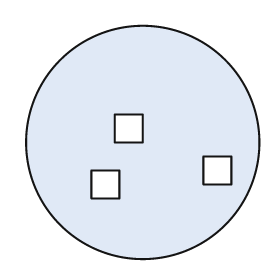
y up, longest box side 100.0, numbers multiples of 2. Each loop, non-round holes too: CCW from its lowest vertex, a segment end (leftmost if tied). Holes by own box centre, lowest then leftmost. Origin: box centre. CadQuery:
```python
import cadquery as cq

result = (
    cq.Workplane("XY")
    .moveTo(0.0, 0.0)
    .circle(50.0)
    .moveTo(-22.0, -24.0)
    .lineTo(-10.0, -24.0)
    .lineTo(-10.0, -12.0)
    .lineTo(-22.0, -12.0)
    .close()
    .moveTo(26.0, -18.0)
    .lineTo(38.0, -18.0)
    .lineTo(38.0, -6.0)
    .lineTo(26.0, -6.0)
    .close()
    .moveTo(-12.0, 0.0)
    .lineTo(0.0, 0.0)
    .lineTo(0.0, 12.0)
    .lineTo(-12.0, 12.0)
    .close()
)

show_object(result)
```